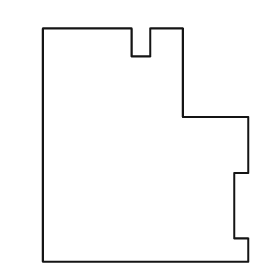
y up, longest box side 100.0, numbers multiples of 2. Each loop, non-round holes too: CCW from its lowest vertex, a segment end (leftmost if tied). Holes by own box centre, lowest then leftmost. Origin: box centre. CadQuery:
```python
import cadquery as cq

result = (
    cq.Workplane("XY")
    .moveTo(-44.0, -50.0)
    .lineTo(44.0, -50.0)
    .lineTo(44.0, -40.0)
    .lineTo(38.0, -40.0)
    .lineTo(38.0, -12.0)
    .lineTo(44.0, -12.0)
    .lineTo(44.0, 12.0)
    .lineTo(16.0, 12.0)
    .lineTo(16.0, 50.0)
    .lineTo(2.0, 50.0)
    .lineTo(2.0, 38.0)
    .lineTo(-6.0, 38.0)
    .lineTo(-6.0, 50.0)
    .lineTo(-44.0, 50.0)
    .close()
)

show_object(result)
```